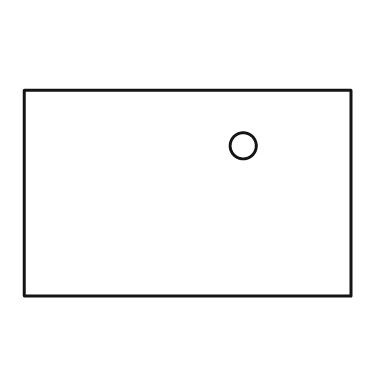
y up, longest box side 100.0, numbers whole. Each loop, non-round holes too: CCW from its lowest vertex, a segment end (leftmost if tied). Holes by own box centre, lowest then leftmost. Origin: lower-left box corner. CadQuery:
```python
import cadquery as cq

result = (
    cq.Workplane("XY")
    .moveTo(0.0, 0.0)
    .lineTo(100.0, 0.0)
    .lineTo(100.0, 63.0)
    .lineTo(0.0, 63.0)
    .close()
    .moveTo(67.0, 46.0)
    .circle(4.0)
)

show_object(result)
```